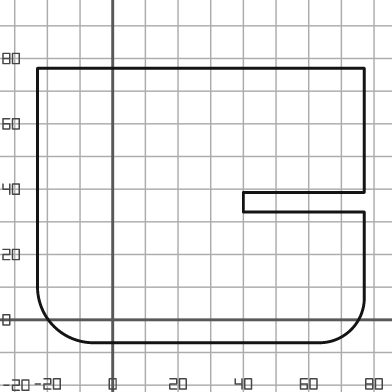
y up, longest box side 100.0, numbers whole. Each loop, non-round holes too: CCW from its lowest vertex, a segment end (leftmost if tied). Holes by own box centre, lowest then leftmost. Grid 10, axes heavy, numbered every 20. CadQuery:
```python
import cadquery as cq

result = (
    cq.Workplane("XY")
    .moveTo(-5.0, -7.0)
    .lineTo(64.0, -7.0)
    .threePointArc((73.0, -3.0), (77.0, 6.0))
    .lineTo(77.0, 33.0)
    .lineTo(40.0, 33.0)
    .lineTo(40.0, 39.0)
    .lineTo(77.0, 39.0)
    .lineTo(77.0, 77.0)
    .lineTo(-23.0, 77.0)
    .lineTo(-23.0, 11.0)
    .threePointArc((-18.0, -2.0), (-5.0, -7.0))
    .close()
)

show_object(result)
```